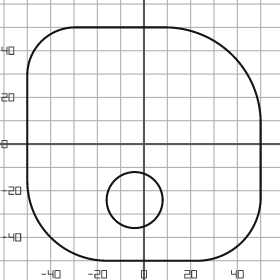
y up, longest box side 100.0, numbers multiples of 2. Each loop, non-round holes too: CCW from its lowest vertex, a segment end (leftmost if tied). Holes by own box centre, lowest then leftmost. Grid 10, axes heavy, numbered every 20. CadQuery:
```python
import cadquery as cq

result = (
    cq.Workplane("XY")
    .moveTo(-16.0, -50.0)
    .lineTo(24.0, -50.0)
    .threePointArc((42.0, -42.0), (50.0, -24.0))
    .lineTo(50.0, 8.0)
    .threePointArc((38.0, 38.0), (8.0, 50.0))
    .lineTo(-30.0, 50.0)
    .threePointArc((-44.0, 44.0), (-50.0, 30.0))
    .lineTo(-50.0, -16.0)
    .threePointArc((-40.0, -40.0), (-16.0, -50.0))
    .close()
    .moveTo(-4.0, -24.0)
    .circle(12.0)
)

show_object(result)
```